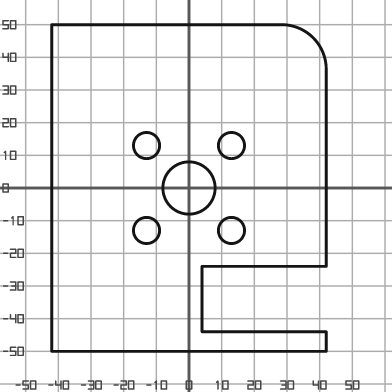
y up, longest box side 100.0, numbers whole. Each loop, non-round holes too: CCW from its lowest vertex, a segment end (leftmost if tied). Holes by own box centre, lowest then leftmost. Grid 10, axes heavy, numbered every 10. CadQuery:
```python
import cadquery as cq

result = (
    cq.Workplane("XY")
    .moveTo(-42.0, -50.0)
    .lineTo(42.0, -50.0)
    .lineTo(42.0, -44.0)
    .lineTo(4.0, -44.0)
    .lineTo(4.0, -24.0)
    .lineTo(42.0, -24.0)
    .lineTo(42.0, 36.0)
    .threePointArc((38.0, 46.0), (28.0, 50.0))
    .lineTo(-42.0, 50.0)
    .close()
    .moveTo(-13.0, -13.0)
    .circle(4.0)
    .moveTo(13.0, -13.0)
    .circle(4.0)
    .moveTo(0.0, 0.0)
    .circle(8.0)
    .moveTo(-13.0, 13.0)
    .circle(4.0)
    .moveTo(13.0, 13.0)
    .circle(4.0)
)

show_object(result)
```